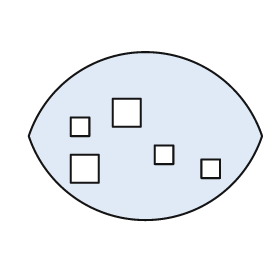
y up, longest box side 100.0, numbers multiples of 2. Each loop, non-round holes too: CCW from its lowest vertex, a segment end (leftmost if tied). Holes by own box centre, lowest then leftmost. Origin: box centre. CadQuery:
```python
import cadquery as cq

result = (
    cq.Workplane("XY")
    .moveTo(-50.0, 0.0)
    .threePointArc((0.0, -36.0), (50.0, 0.0))
    .threePointArc((0.0, 36.0), (-50.0, 0.0))
    .close()
    .moveTo(-32.0, -20.0)
    .lineTo(-20.0, -20.0)
    .lineTo(-20.0, -8.0)
    .lineTo(-32.0, -8.0)
    .close()
    .moveTo(24.0, -18.0)
    .lineTo(32.0, -18.0)
    .lineTo(32.0, -10.0)
    .lineTo(24.0, -10.0)
    .close()
    .moveTo(4.0, -12.0)
    .lineTo(12.0, -12.0)
    .lineTo(12.0, -4.0)
    .lineTo(4.0, -4.0)
    .close()
    .moveTo(-32.0, 0.0)
    .lineTo(-24.0, 0.0)
    .lineTo(-24.0, 8.0)
    .lineTo(-32.0, 8.0)
    .close()
    .moveTo(-14.0, 4.0)
    .lineTo(-2.0, 4.0)
    .lineTo(-2.0, 16.0)
    .lineTo(-14.0, 16.0)
    .close()
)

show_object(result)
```